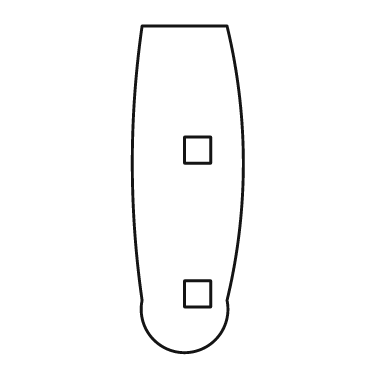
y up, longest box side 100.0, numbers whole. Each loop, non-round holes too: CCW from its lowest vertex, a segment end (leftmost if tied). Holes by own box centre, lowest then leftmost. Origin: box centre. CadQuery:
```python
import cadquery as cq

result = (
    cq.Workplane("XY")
    .moveTo(-14.0, -34.0)
    .threePointArc((-1.0, -50.0), (12.0, -34.0))
    .threePointArc((17.0, 8.0), (12.0, 50.0))
    .lineTo(-14.0, 50.0)
    .threePointArc((-17.0, 8.0), (-14.0, -34.0))
    .close()
    .moveTo(-1.0, -36.0)
    .lineTo(7.0, -36.0)
    .lineTo(7.0, -28.0)
    .lineTo(-1.0, -28.0)
    .close()
    .moveTo(-1.0, 8.0)
    .lineTo(7.0, 8.0)
    .lineTo(7.0, 16.0)
    .lineTo(-1.0, 16.0)
    .close()
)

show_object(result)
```